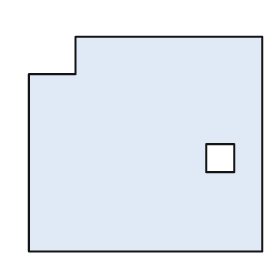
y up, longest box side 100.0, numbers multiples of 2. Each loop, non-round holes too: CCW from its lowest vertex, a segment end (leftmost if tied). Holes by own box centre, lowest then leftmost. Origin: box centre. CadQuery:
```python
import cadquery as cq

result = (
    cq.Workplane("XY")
    .moveTo(-50.0, -46.0)
    .lineTo(50.0, -46.0)
    .lineTo(50.0, 46.0)
    .lineTo(-30.0, 46.0)
    .lineTo(-30.0, 30.0)
    .lineTo(-50.0, 30.0)
    .close()
    .moveTo(26.0, -12.0)
    .lineTo(38.0, -12.0)
    .lineTo(38.0, 0.0)
    .lineTo(26.0, 0.0)
    .close()
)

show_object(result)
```